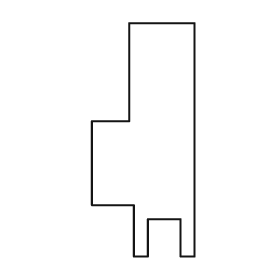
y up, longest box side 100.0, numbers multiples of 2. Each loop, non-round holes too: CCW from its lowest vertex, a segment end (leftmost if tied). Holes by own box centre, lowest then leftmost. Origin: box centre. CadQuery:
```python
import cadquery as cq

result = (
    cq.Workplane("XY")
    .moveTo(-4.0, -50.0)
    .lineTo(2.0, -50.0)
    .lineTo(2.0, -34.0)
    .lineTo(16.0, -34.0)
    .lineTo(16.0, -50.0)
    .lineTo(22.0, -50.0)
    .lineTo(22.0, 50.0)
    .lineTo(-6.0, 50.0)
    .lineTo(-6.0, 8.0)
    .lineTo(-22.0, 8.0)
    .lineTo(-22.0, -28.0)
    .lineTo(-4.0, -28.0)
    .close()
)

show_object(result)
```